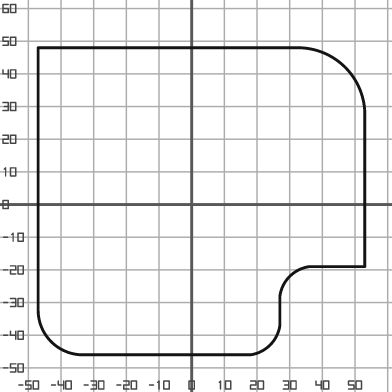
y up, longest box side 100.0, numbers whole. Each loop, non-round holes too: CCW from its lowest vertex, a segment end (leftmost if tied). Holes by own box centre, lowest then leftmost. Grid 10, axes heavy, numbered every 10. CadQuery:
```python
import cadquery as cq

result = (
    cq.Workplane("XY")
    .moveTo(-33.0, -46.0)
    .lineTo(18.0, -46.0)
    .threePointArc((24.0, -43.0), (27.0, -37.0))
    .lineTo(27.0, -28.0)
    .threePointArc((30.0, -22.0), (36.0, -19.0))
    .lineTo(53.0, -19.0)
    .lineTo(53.0, 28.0)
    .threePointArc((47.0, 42.0), (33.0, 48.0))
    .lineTo(-47.0, 48.0)
    .lineTo(-47.0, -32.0)
    .threePointArc((-43.0, -42.0), (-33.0, -46.0))
    .close()
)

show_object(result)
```